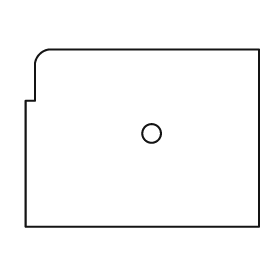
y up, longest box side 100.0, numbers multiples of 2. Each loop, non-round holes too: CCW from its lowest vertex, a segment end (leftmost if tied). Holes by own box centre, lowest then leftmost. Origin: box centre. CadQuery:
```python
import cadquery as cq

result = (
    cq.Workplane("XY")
    .moveTo(-50.0, -38.0)
    .lineTo(50.0, -38.0)
    .lineTo(50.0, 38.0)
    .lineTo(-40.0, 38.0)
    .threePointArc((-44.0, 36.0), (-46.0, 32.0))
    .lineTo(-46.0, 16.0)
    .lineTo(-50.0, 16.0)
    .close()
    .moveTo(4.0, 2.0)
    .circle(4.0)
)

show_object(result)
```